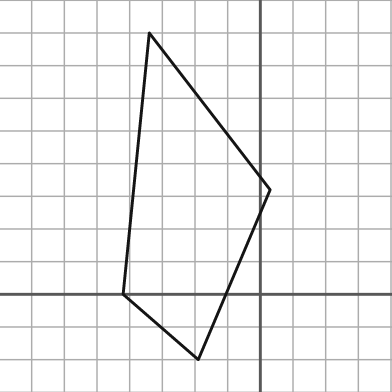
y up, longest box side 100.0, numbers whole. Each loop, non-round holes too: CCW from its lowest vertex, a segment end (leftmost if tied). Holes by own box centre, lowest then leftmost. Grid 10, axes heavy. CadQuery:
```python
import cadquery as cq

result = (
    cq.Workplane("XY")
    .moveTo(-19.0, -20.0)
    .lineTo(3.0, 32.0)
    .lineTo(-34.0, 80.0)
    .lineTo(-42.0, 0.0)
    .close()
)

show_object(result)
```